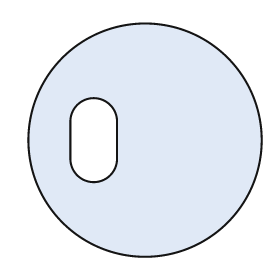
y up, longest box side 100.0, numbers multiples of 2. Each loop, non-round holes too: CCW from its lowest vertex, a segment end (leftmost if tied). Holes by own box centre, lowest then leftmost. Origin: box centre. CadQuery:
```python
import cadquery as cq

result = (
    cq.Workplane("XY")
    .moveTo(0.0, 0.0)
    .circle(50.0)
    .moveTo(-32.0, -8.0)
    .threePointArc((-22.0, -18.0), (-12.0, -8.0))
    .lineTo(-12.0, 8.0)
    .threePointArc((-22.0, 18.0), (-32.0, 8.0))
    .close()
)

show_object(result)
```